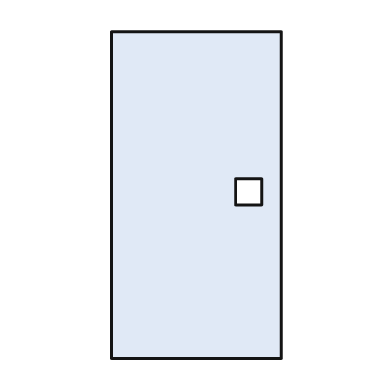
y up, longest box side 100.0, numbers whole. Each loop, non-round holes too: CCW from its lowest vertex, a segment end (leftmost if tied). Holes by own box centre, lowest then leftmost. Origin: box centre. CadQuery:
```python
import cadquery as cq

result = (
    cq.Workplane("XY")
    .moveTo(-26.0, -50.0)
    .lineTo(26.0, -50.0)
    .lineTo(26.0, 50.0)
    .lineTo(-26.0, 50.0)
    .close()
    .moveTo(12.0, -3.0)
    .lineTo(20.0, -3.0)
    .lineTo(20.0, 5.0)
    .lineTo(12.0, 5.0)
    .close()
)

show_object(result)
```